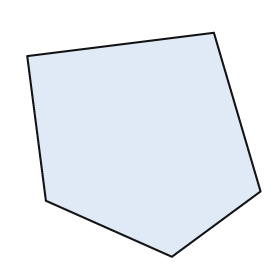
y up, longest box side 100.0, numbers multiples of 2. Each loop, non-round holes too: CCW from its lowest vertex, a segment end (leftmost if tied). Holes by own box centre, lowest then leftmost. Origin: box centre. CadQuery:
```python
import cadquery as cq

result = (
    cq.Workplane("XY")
    .moveTo(12.0, -48.0)
    .lineTo(50.0, -20.0)
    .lineTo(30.0, 48.0)
    .lineTo(-50.0, 38.0)
    .lineTo(-42.0, -24.0)
    .close()
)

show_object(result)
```